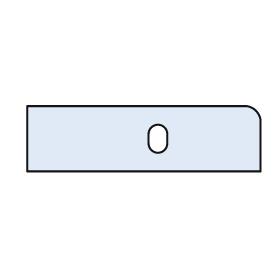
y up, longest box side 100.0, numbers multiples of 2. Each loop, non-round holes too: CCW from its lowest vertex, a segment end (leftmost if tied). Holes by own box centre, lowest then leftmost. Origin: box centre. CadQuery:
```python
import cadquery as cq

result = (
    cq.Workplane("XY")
    .moveTo(-50.0, -14.0)
    .lineTo(50.0, -14.0)
    .lineTo(50.0, 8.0)
    .threePointArc((48.0, 12.0), (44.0, 14.0))
    .lineTo(-50.0, 14.0)
    .close()
    .moveTo(2.0, -2.0)
    .threePointArc((6.0, -6.0), (10.0, -2.0))
    .lineTo(10.0, 2.0)
    .threePointArc((6.0, 6.0), (2.0, 2.0))
    .close()
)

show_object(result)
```